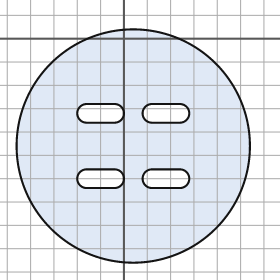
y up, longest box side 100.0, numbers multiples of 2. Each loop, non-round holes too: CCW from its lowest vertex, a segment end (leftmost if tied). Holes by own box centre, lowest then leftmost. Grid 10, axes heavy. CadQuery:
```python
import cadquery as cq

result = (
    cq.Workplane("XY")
    .moveTo(4.0, -46.0)
    .circle(50.0)
    .moveTo(-16.0, -64.0)
    .lineTo(-4.0, -64.0)
    .threePointArc((0.0, -60.0), (-4.0, -56.0))
    .lineTo(-16.0, -56.0)
    .threePointArc((-20.0, -60.0), (-16.0, -64.0))
    .close()
    .moveTo(12.0, -64.0)
    .lineTo(24.0, -64.0)
    .threePointArc((28.0, -60.0), (24.0, -56.0))
    .lineTo(12.0, -56.0)
    .threePointArc((8.0, -60.0), (12.0, -64.0))
    .close()
    .moveTo(-16.0, -36.0)
    .lineTo(-4.0, -36.0)
    .threePointArc((0.0, -32.0), (-4.0, -28.0))
    .lineTo(-16.0, -28.0)
    .threePointArc((-20.0, -32.0), (-16.0, -36.0))
    .close()
    .moveTo(12.0, -36.0)
    .lineTo(24.0, -36.0)
    .threePointArc((28.0, -32.0), (24.0, -28.0))
    .lineTo(12.0, -28.0)
    .threePointArc((8.0, -32.0), (12.0, -36.0))
    .close()
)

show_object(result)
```